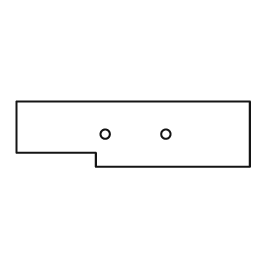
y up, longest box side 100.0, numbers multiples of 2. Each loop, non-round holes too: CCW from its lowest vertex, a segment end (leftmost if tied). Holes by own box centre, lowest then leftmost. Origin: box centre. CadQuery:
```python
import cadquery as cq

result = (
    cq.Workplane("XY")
    .moveTo(-16.0, -14.0)
    .lineTo(50.0, -14.0)
    .lineTo(50.0, 14.0)
    .lineTo(-50.0, 14.0)
    .lineTo(-50.0, -8.0)
    .lineTo(-16.0, -8.0)
    .close()
    .moveTo(-12.0, 0.0)
    .circle(2.0)
    .moveTo(14.0, 0.0)
    .circle(2.0)
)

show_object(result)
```